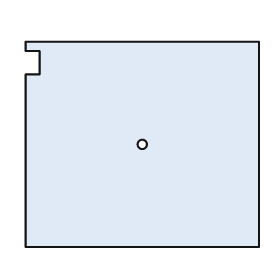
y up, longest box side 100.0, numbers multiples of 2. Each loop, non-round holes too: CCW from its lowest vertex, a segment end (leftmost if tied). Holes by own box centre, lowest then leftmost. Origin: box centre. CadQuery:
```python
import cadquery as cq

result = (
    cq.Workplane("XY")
    .moveTo(-50.0, -44.0)
    .lineTo(50.0, -44.0)
    .lineTo(50.0, 44.0)
    .lineTo(-50.0, 44.0)
    .lineTo(-50.0, 40.0)
    .lineTo(-44.0, 40.0)
    .lineTo(-44.0, 30.0)
    .lineTo(-50.0, 30.0)
    .close()
    .moveTo(0.0, 0.0)
    .circle(2.0)
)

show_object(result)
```